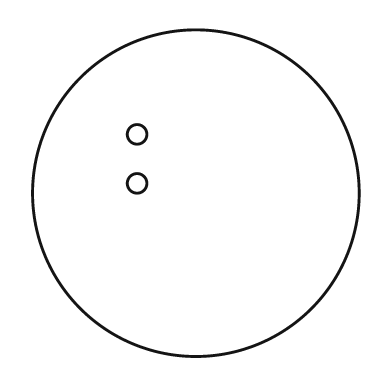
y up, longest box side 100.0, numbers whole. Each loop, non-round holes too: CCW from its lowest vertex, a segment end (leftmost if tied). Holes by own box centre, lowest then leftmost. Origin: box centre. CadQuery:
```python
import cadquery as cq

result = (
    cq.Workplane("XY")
    .moveTo(0.0, 0.0)
    .circle(50.0)
    .moveTo(-18.0, 3.0)
    .circle(3.0)
    .moveTo(-18.0, 18.0)
    .circle(3.0)
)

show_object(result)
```